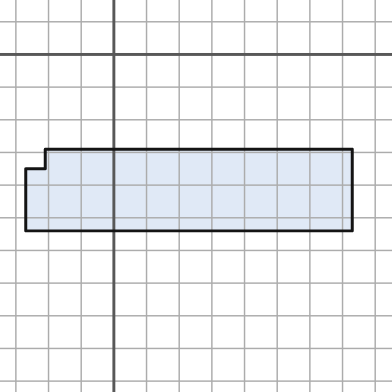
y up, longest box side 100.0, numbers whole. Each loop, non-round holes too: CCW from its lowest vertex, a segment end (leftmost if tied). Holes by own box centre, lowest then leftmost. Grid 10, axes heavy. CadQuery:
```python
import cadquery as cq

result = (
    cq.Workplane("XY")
    .moveTo(-27.0, -54.0)
    .lineTo(73.0, -54.0)
    .lineTo(73.0, -29.0)
    .lineTo(-21.0, -29.0)
    .lineTo(-21.0, -35.0)
    .lineTo(-27.0, -35.0)
    .close()
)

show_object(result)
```